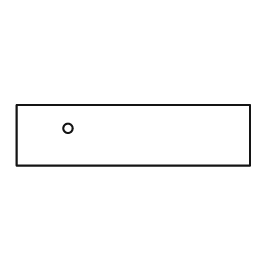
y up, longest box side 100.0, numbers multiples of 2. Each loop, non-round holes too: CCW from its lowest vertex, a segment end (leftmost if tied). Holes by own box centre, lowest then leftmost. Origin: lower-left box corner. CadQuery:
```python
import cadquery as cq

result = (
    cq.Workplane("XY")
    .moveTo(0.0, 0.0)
    .lineTo(100.0, 0.0)
    .lineTo(100.0, 26.0)
    .lineTo(0.0, 26.0)
    .close()
    .moveTo(22.0, 16.0)
    .circle(2.0)
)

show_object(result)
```